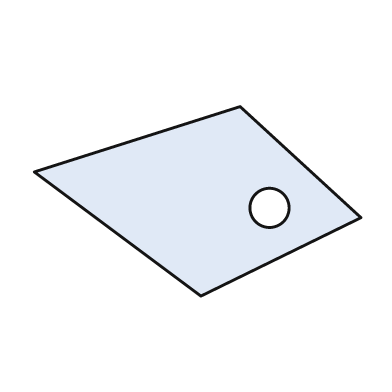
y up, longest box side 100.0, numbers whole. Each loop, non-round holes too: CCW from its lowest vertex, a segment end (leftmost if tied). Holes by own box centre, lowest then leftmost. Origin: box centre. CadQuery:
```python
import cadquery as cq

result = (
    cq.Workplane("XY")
    .moveTo(1.0, -29.0)
    .lineTo(50.0, -5.0)
    .lineTo(13.0, 29.0)
    .lineTo(-50.0, 9.0)
    .close()
    .moveTo(22.0, -2.0)
    .circle(6.0)
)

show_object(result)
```